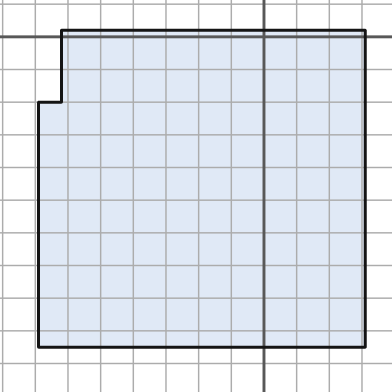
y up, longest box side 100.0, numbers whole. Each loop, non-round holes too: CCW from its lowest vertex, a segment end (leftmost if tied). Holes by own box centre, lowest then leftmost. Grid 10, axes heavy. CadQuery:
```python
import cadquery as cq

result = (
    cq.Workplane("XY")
    .moveTo(-69.0, -95.0)
    .lineTo(31.0, -95.0)
    .lineTo(31.0, 2.0)
    .lineTo(-62.0, 2.0)
    .lineTo(-62.0, -20.0)
    .lineTo(-69.0, -20.0)
    .close()
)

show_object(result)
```